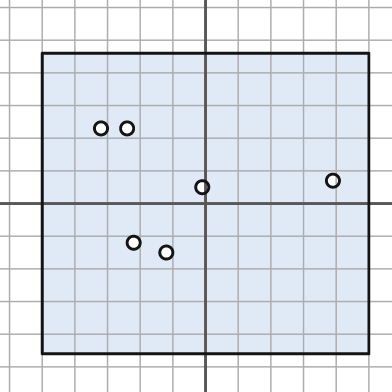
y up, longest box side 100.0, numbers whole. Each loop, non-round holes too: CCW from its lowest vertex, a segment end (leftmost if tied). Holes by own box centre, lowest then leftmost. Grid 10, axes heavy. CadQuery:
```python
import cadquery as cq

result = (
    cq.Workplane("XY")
    .moveTo(-50.0, -46.0)
    .lineTo(50.0, -46.0)
    .lineTo(50.0, 46.0)
    .lineTo(-50.0, 46.0)
    .close()
    .moveTo(-12.0, -15.0)
    .circle(2.0)
    .moveTo(-22.0, -12.0)
    .circle(2.0)
    .moveTo(-1.0, 5.0)
    .circle(2.0)
    .moveTo(39.0, 7.0)
    .circle(2.0)
    .moveTo(-32.0, 23.0)
    .circle(2.0)
    .moveTo(-24.0, 23.0)
    .circle(2.0)
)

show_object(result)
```